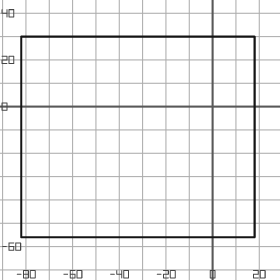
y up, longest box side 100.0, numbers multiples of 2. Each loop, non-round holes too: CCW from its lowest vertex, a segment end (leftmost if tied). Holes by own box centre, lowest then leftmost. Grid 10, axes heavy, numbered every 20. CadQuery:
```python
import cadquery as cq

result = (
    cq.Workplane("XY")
    .moveTo(-82.0, -56.0)
    .lineTo(18.0, -56.0)
    .lineTo(18.0, 30.0)
    .lineTo(-82.0, 30.0)
    .close()
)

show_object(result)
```